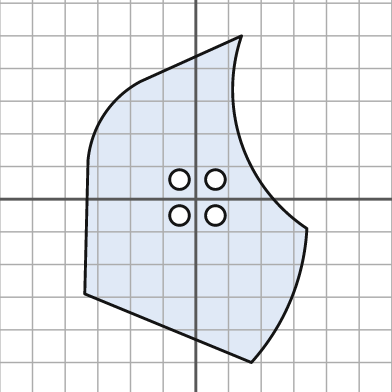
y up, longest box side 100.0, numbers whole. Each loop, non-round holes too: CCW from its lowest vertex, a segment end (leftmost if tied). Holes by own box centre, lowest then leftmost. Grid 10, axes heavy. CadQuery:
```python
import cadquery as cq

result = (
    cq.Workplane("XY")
    .moveTo(17.0, -50.0)
    .threePointArc((29.0, -31.0), (34.0, -9.0))
    .threePointArc((14.0, 17.0), (14.0, 50.0))
    .lineTo(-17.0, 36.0)
    .threePointArc((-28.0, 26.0), (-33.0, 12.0))
    .lineTo(-34.0, -29.0)
    .close()
    .moveTo(-5.0, -5.0)
    .circle(3.0)
    .moveTo(6.0, -5.0)
    .circle(3.0)
    .moveTo(-5.0, 6.0)
    .circle(3.0)
    .moveTo(6.0, 6.0)
    .circle(3.0)
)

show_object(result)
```